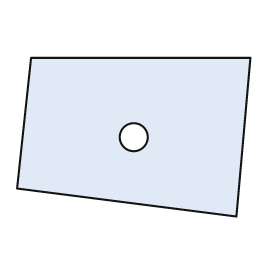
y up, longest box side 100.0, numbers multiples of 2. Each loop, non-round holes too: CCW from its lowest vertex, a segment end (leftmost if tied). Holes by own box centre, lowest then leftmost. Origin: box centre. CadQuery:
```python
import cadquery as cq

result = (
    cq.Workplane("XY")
    .moveTo(44.0, -34.0)
    .lineTo(50.0, 34.0)
    .lineTo(-44.0, 34.0)
    .lineTo(-50.0, -22.0)
    .close()
    .moveTo(0.0, 0.0)
    .circle(6.0)
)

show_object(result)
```